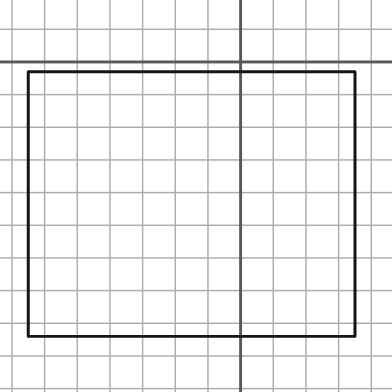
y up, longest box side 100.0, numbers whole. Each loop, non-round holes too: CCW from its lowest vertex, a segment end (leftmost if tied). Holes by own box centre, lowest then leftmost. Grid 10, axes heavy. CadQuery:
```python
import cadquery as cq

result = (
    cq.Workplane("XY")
    .moveTo(-65.0, -84.0)
    .lineTo(35.0, -84.0)
    .lineTo(35.0, -3.0)
    .lineTo(-65.0, -3.0)
    .close()
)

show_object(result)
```